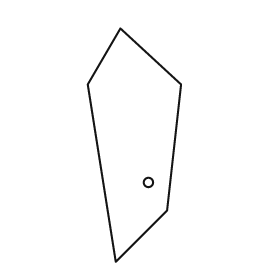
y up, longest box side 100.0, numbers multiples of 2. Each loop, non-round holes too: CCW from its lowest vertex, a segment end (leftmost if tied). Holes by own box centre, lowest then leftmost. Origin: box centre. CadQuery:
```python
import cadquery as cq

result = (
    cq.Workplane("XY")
    .moveTo(-8.0, -50.0)
    .lineTo(14.0, -28.0)
    .lineTo(20.0, 26.0)
    .lineTo(-6.0, 50.0)
    .lineTo(-20.0, 26.0)
    .close()
    .moveTo(6.0, -16.0)
    .circle(2.0)
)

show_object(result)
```